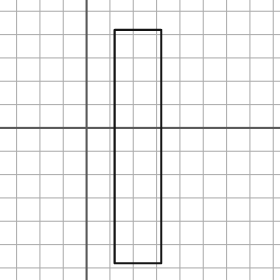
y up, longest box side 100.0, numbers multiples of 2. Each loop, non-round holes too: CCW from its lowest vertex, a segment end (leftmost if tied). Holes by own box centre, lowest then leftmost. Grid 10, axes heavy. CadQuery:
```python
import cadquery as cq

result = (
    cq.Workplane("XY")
    .moveTo(12.0, -58.0)
    .lineTo(32.0, -58.0)
    .lineTo(32.0, 42.0)
    .lineTo(12.0, 42.0)
    .close()
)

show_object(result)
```